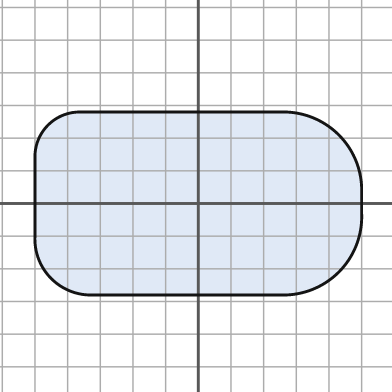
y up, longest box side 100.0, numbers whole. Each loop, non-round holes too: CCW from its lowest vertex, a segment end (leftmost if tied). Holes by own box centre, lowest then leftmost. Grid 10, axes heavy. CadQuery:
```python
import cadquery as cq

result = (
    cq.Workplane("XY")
    .moveTo(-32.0, -28.0)
    .lineTo(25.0, -28.0)
    .threePointArc((43.0, -21.0), (50.0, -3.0))
    .lineTo(50.0, 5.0)
    .threePointArc((43.0, 21.0), (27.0, 28.0))
    .lineTo(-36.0, 28.0)
    .threePointArc((-46.0, 24.0), (-50.0, 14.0))
    .lineTo(-50.0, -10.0)
    .threePointArc((-45.0, -23.0), (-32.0, -28.0))
    .close()
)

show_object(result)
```